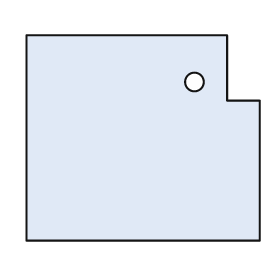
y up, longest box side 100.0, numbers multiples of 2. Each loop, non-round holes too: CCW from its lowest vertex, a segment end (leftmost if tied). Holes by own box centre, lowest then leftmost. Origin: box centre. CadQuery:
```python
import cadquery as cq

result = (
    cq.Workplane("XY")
    .moveTo(-50.0, -44.0)
    .lineTo(50.0, -44.0)
    .lineTo(50.0, 16.0)
    .lineTo(36.0, 16.0)
    .lineTo(36.0, 44.0)
    .lineTo(-50.0, 44.0)
    .close()
    .moveTo(22.0, 24.0)
    .circle(4.0)
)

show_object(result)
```